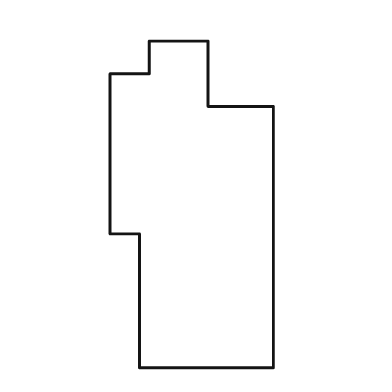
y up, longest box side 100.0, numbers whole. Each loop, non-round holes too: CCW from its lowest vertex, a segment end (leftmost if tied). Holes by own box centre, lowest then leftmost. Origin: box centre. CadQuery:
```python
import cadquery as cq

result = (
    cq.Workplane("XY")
    .moveTo(-16.0, -50.0)
    .lineTo(25.0, -50.0)
    .lineTo(25.0, 30.0)
    .lineTo(5.0, 30.0)
    .lineTo(5.0, 50.0)
    .lineTo(-13.0, 50.0)
    .lineTo(-13.0, 40.0)
    .lineTo(-25.0, 40.0)
    .lineTo(-25.0, -9.0)
    .lineTo(-16.0, -9.0)
    .close()
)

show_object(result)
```